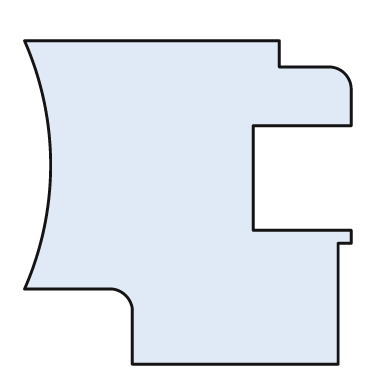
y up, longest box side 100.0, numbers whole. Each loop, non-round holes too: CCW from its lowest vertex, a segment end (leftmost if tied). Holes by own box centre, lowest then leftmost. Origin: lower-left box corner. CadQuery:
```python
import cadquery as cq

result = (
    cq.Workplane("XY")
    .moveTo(33.0, 0.0)
    .lineTo(96.0, 0.0)
    .lineTo(96.0, 37.0)
    .lineTo(100.0, 37.0)
    .lineTo(100.0, 41.0)
    .lineTo(70.0, 41.0)
    .lineTo(70.0, 73.0)
    .lineTo(100.0, 73.0)
    .lineTo(100.0, 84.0)
    .threePointArc((98.0, 89.0), (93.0, 91.0))
    .lineTo(78.0, 91.0)
    .lineTo(78.0, 99.0)
    .lineTo(0.0, 99.0)
    .threePointArc((8.0, 61.0), (0.0, 23.0))
    .lineTo(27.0, 23.0)
    .threePointArc((31.0, 21.0), (33.0, 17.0))
    .close()
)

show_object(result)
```